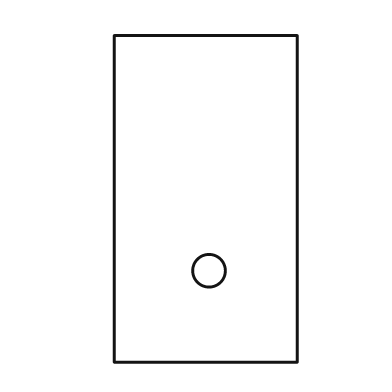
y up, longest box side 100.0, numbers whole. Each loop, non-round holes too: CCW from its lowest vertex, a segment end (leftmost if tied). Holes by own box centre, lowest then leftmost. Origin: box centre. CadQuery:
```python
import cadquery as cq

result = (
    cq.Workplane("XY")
    .moveTo(-28.0, -50.0)
    .lineTo(28.0, -50.0)
    .lineTo(28.0, 50.0)
    .lineTo(-28.0, 50.0)
    .close()
    .moveTo(1.0, -22.0)
    .circle(5.0)
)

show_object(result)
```